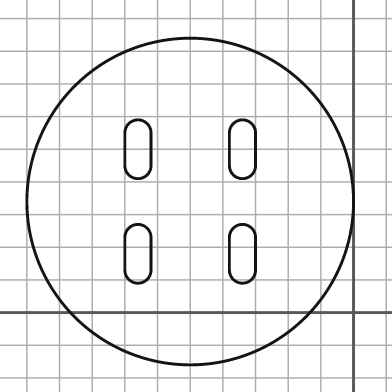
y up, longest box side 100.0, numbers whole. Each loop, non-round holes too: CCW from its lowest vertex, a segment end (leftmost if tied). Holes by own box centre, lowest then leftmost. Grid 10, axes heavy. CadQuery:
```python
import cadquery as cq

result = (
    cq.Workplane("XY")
    .moveTo(-50.0, 34.0)
    .circle(50.0)
    .moveTo(-70.0, 13.0)
    .threePointArc((-66.0, 9.0), (-62.0, 13.0))
    .lineTo(-62.0, 23.0)
    .threePointArc((-66.0, 27.0), (-70.0, 23.0))
    .close()
    .moveTo(-38.0, 13.0)
    .threePointArc((-34.0, 9.0), (-30.0, 13.0))
    .lineTo(-30.0, 23.0)
    .threePointArc((-34.0, 27.0), (-38.0, 23.0))
    .close()
    .moveTo(-70.0, 45.0)
    .threePointArc((-66.0, 41.0), (-62.0, 45.0))
    .lineTo(-62.0, 55.0)
    .threePointArc((-66.0, 59.0), (-70.0, 55.0))
    .close()
    .moveTo(-38.0, 45.0)
    .threePointArc((-34.0, 41.0), (-30.0, 45.0))
    .lineTo(-30.0, 55.0)
    .threePointArc((-34.0, 59.0), (-38.0, 55.0))
    .close()
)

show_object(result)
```